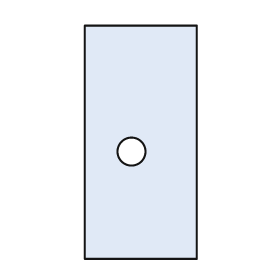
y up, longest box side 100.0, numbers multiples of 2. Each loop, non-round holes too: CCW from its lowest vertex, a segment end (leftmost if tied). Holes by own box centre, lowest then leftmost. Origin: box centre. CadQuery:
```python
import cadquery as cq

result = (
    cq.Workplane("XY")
    .moveTo(-24.0, -50.0)
    .lineTo(24.0, -50.0)
    .lineTo(24.0, 50.0)
    .lineTo(-24.0, 50.0)
    .close()
    .moveTo(-4.0, -4.0)
    .circle(6.0)
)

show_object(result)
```